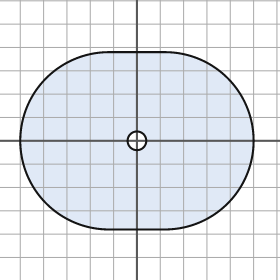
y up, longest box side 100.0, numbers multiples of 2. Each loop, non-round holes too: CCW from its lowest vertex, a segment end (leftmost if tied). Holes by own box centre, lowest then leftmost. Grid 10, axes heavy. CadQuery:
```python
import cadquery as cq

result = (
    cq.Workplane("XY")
    .moveTo(-12.0, -38.0)
    .lineTo(12.0, -38.0)
    .threePointArc((50.0, 0.0), (12.0, 38.0))
    .lineTo(-12.0, 38.0)
    .threePointArc((-50.0, 0.0), (-12.0, -38.0))
    .close()
    .moveTo(0.0, 0.0)
    .circle(4.0)
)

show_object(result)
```